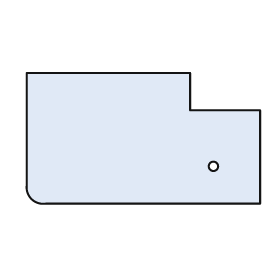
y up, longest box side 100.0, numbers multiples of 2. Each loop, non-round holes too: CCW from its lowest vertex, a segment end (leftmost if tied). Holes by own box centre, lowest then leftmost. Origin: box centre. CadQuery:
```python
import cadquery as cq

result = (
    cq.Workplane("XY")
    .moveTo(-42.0, -28.0)
    .lineTo(50.0, -28.0)
    .lineTo(50.0, 12.0)
    .lineTo(20.0, 12.0)
    .lineTo(20.0, 28.0)
    .lineTo(-50.0, 28.0)
    .lineTo(-50.0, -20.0)
    .threePointArc((-48.0, -26.0), (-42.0, -28.0))
    .close()
    .moveTo(30.0, -12.0)
    .circle(2.0)
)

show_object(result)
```